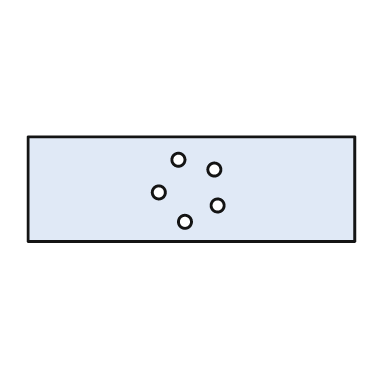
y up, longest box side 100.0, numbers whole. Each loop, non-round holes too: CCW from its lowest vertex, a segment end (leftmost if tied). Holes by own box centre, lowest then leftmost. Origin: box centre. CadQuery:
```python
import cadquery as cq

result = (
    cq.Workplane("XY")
    .moveTo(-50.0, -16.0)
    .lineTo(50.0, -16.0)
    .lineTo(50.0, 16.0)
    .lineTo(-50.0, 16.0)
    .close()
    .moveTo(-2.0, -10.0)
    .circle(2.0)
    .moveTo(8.0, -5.0)
    .circle(2.0)
    .moveTo(-10.0, -1.0)
    .circle(2.0)
    .moveTo(7.0, 6.0)
    .circle(2.0)
    .moveTo(-4.0, 9.0)
    .circle(2.0)
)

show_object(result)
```